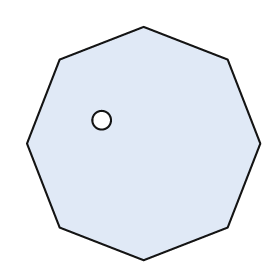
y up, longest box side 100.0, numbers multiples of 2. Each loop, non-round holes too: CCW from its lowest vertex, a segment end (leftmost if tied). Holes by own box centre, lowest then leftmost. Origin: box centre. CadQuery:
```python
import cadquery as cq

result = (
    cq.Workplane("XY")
    .moveTo(0.0, -50.0)
    .lineTo(36.0, -36.0)
    .lineTo(50.0, 0.0)
    .lineTo(36.0, 36.0)
    .lineTo(0.0, 50.0)
    .lineTo(-36.0, 36.0)
    .lineTo(-50.0, 0.0)
    .lineTo(-36.0, -36.0)
    .close()
    .moveTo(-18.0, 10.0)
    .circle(4.0)
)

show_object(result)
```